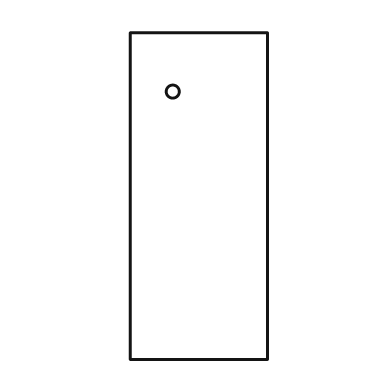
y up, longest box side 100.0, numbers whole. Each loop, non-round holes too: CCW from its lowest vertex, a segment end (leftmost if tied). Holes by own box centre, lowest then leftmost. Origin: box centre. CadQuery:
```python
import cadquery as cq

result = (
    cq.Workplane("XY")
    .moveTo(-21.0, -50.0)
    .lineTo(21.0, -50.0)
    .lineTo(21.0, 50.0)
    .lineTo(-21.0, 50.0)
    .close()
    .moveTo(-8.0, 32.0)
    .circle(2.0)
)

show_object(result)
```